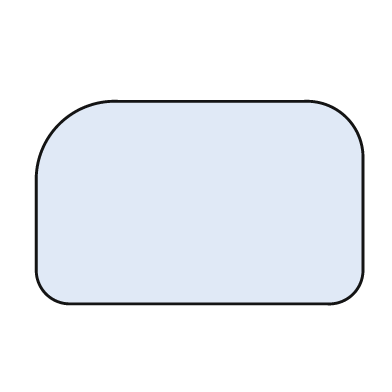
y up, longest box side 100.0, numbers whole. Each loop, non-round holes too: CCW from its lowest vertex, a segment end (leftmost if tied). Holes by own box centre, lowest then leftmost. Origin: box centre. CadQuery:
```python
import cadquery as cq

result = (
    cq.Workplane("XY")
    .moveTo(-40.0, -31.0)
    .lineTo(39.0, -31.0)
    .threePointArc((47.0, -28.0), (50.0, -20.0))
    .lineTo(50.0, 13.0)
    .threePointArc((45.0, 26.0), (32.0, 31.0))
    .lineTo(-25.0, 31.0)
    .threePointArc((-43.0, 24.0), (-50.0, 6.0))
    .lineTo(-50.0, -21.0)
    .threePointArc((-47.0, -28.0), (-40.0, -31.0))
    .close()
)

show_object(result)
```